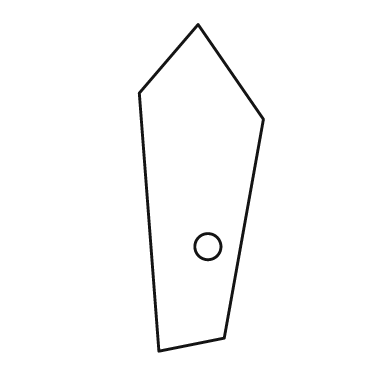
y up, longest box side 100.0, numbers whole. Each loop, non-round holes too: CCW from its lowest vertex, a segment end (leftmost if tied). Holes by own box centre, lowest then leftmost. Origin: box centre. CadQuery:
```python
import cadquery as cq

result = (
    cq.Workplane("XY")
    .moveTo(-13.0, -50.0)
    .lineTo(7.0, -46.0)
    .lineTo(19.0, 21.0)
    .lineTo(-1.0, 50.0)
    .lineTo(-19.0, 29.0)
    .close()
    .moveTo(2.0, -18.0)
    .circle(4.0)
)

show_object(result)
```